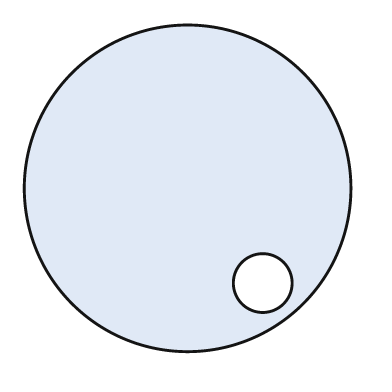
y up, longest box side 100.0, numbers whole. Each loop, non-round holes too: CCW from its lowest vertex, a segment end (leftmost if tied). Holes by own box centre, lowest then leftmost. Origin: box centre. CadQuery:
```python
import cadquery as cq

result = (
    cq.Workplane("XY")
    .moveTo(0.0, 0.0)
    .circle(50.0)
    .moveTo(23.0, -29.0)
    .circle(9.0)
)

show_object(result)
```